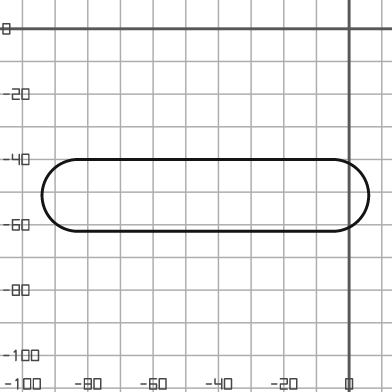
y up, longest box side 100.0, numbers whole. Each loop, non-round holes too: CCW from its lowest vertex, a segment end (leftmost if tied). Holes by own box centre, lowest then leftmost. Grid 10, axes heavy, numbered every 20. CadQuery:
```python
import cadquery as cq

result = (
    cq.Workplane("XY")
    .moveTo(-83.0, -62.0)
    .lineTo(-5.0, -62.0)
    .threePointArc((6.0, -51.0), (-5.0, -40.0))
    .lineTo(-83.0, -40.0)
    .threePointArc((-94.0, -51.0), (-83.0, -62.0))
    .close()
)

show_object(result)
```